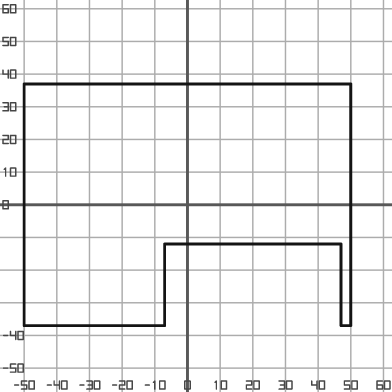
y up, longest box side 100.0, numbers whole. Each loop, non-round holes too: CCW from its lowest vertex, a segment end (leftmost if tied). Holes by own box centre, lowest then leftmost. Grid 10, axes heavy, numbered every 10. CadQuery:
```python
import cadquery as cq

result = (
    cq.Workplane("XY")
    .moveTo(-50.0, -37.0)
    .lineTo(-7.0, -37.0)
    .lineTo(-7.0, -12.0)
    .lineTo(47.0, -12.0)
    .lineTo(47.0, -37.0)
    .lineTo(50.0, -37.0)
    .lineTo(50.0, 37.0)
    .lineTo(-50.0, 37.0)
    .close()
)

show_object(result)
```